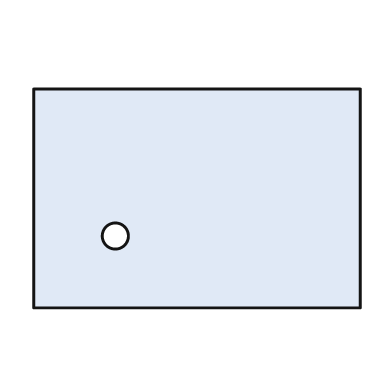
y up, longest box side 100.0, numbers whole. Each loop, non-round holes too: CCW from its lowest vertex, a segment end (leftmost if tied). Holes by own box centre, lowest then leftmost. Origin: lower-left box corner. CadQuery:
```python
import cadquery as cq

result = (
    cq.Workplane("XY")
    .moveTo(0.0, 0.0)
    .lineTo(100.0, 0.0)
    .lineTo(100.0, 67.0)
    .lineTo(0.0, 67.0)
    .close()
    .moveTo(25.0, 22.0)
    .circle(4.0)
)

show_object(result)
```